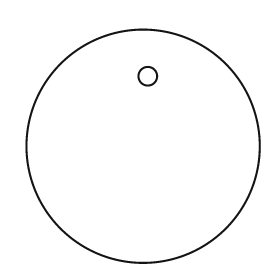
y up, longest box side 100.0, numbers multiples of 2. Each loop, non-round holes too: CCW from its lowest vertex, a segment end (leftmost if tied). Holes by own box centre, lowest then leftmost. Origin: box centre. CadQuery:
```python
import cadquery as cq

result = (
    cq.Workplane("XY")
    .moveTo(0.0, 0.0)
    .circle(50.0)
    .moveTo(2.0, 30.0)
    .circle(4.0)
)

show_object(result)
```